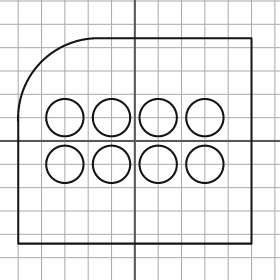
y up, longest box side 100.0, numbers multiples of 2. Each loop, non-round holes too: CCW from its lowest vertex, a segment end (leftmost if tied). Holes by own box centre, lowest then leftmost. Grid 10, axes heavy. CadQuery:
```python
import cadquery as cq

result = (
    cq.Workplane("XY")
    .moveTo(-50.0, -44.0)
    .lineTo(50.0, -44.0)
    .lineTo(50.0, 44.0)
    .lineTo(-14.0, 44.0)
    .threePointArc((-40.0, 34.0), (-50.0, 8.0))
    .close()
    .moveTo(-30.0, -10.0)
    .circle(8.0)
    .moveTo(-10.0, -10.0)
    .circle(8.0)
    .moveTo(10.0, -10.0)
    .circle(8.0)
    .moveTo(30.0, -10.0)
    .circle(8.0)
    .moveTo(-30.0, 10.0)
    .circle(8.0)
    .moveTo(-10.0, 10.0)
    .circle(8.0)
    .moveTo(10.0, 10.0)
    .circle(8.0)
    .moveTo(30.0, 10.0)
    .circle(8.0)
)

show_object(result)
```